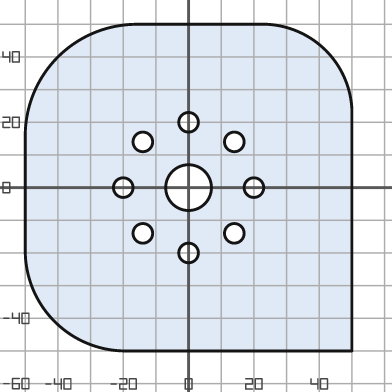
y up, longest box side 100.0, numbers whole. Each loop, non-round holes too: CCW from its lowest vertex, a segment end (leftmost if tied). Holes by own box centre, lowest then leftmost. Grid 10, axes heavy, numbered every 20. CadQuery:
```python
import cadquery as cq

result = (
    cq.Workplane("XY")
    .moveTo(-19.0, -50.0)
    .lineTo(50.0, -50.0)
    .lineTo(50.0, 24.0)
    .threePointArc((42.0, 42.0), (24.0, 50.0))
    .lineTo(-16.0, 50.0)
    .threePointArc((-40.0, 40.0), (-50.0, 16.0))
    .lineTo(-50.0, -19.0)
    .threePointArc((-41.0, -41.0), (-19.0, -50.0))
    .close()
    .moveTo(0.0, -20.0)
    .circle(3.0)
    .moveTo(-14.0, -14.0)
    .circle(3.0)
    .moveTo(14.0, -14.0)
    .circle(3.0)
    .moveTo(-20.0, 0.0)
    .circle(3.0)
    .moveTo(0.0, 0.0)
    .circle(7.0)
    .moveTo(20.0, 0.0)
    .circle(3.0)
    .moveTo(-14.0, 14.0)
    .circle(3.0)
    .moveTo(14.0, 14.0)
    .circle(3.0)
    .moveTo(0.0, 20.0)
    .circle(3.0)
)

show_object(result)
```